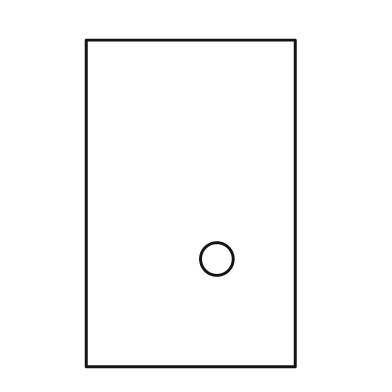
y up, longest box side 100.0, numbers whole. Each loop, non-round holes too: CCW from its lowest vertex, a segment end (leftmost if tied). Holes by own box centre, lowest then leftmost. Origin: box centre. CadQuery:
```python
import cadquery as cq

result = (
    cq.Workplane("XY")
    .moveTo(-32.0, -50.0)
    .lineTo(32.0, -50.0)
    .lineTo(32.0, 50.0)
    .lineTo(-32.0, 50.0)
    .close()
    .moveTo(8.0, -17.0)
    .circle(5.0)
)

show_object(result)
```